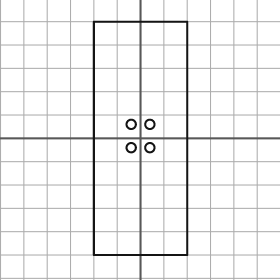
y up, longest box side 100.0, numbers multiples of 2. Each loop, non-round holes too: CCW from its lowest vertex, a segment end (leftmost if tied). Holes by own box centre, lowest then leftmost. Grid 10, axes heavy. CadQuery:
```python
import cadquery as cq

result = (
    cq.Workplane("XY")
    .moveTo(-20.0, -50.0)
    .lineTo(20.0, -50.0)
    .lineTo(20.0, 50.0)
    .lineTo(-20.0, 50.0)
    .close()
    .moveTo(-4.0, -4.0)
    .circle(2.0)
    .moveTo(4.0, -4.0)
    .circle(2.0)
    .moveTo(-4.0, 6.0)
    .circle(2.0)
    .moveTo(4.0, 6.0)
    .circle(2.0)
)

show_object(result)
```